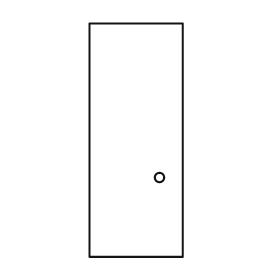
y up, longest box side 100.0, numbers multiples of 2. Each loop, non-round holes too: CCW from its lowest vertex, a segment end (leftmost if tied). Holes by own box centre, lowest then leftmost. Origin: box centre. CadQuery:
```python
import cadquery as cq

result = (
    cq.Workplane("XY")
    .moveTo(-20.0, -50.0)
    .lineTo(20.0, -50.0)
    .lineTo(20.0, 50.0)
    .lineTo(-20.0, 50.0)
    .close()
    .moveTo(10.0, -16.0)
    .circle(2.0)
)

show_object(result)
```